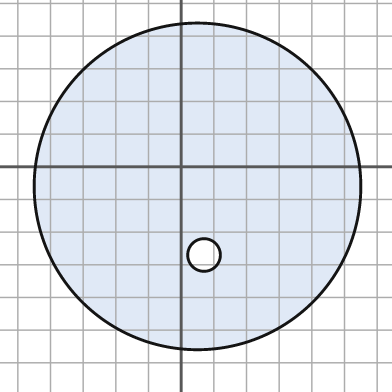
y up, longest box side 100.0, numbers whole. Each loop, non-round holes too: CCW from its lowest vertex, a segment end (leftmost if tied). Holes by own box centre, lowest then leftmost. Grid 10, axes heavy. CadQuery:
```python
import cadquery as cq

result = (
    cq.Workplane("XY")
    .moveTo(5.0, -6.0)
    .circle(50.0)
    .moveTo(7.0, -27.0)
    .circle(5.0)
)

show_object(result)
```